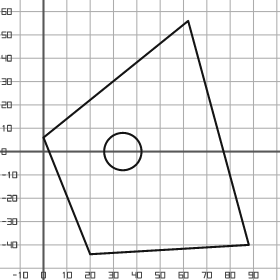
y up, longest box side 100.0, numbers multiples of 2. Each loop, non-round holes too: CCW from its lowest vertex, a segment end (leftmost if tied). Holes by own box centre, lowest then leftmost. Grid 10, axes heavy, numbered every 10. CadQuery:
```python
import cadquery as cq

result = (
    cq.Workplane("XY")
    .moveTo(20.0, -44.0)
    .lineTo(88.0, -40.0)
    .lineTo(62.0, 56.0)
    .lineTo(0.0, 6.0)
    .close()
    .moveTo(34.0, 0.0)
    .circle(8.0)
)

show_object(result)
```